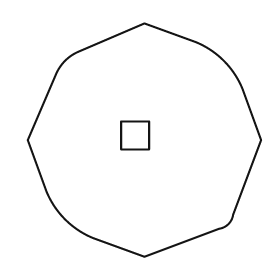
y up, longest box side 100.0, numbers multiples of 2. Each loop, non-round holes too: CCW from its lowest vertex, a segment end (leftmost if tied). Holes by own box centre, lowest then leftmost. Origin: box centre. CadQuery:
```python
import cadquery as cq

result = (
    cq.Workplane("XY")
    .moveTo(0.0, -50.0)
    .lineTo(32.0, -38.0)
    .threePointArc((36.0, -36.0), (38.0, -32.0))
    .lineTo(50.0, 0.0)
    .lineTo(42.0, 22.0)
    .threePointArc((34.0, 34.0), (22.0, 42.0))
    .lineTo(0.0, 50.0)
    .lineTo(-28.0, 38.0)
    .threePointArc((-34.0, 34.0), (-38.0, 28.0))
    .lineTo(-50.0, 0.0)
    .lineTo(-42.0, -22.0)
    .threePointArc((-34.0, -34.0), (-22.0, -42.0))
    .close()
    .moveTo(-10.0, -4.0)
    .lineTo(2.0, -4.0)
    .lineTo(2.0, 8.0)
    .lineTo(-10.0, 8.0)
    .close()
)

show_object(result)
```